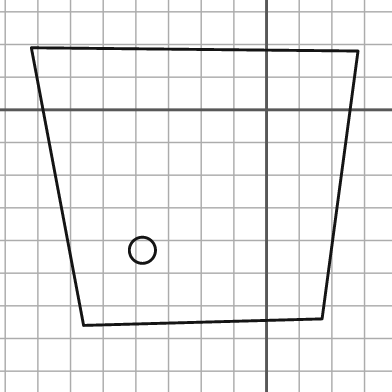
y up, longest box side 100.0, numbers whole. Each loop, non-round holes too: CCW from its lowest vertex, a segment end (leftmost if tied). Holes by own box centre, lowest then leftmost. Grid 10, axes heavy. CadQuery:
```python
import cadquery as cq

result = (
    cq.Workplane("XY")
    .moveTo(-56.0, -66.0)
    .lineTo(17.0, -64.0)
    .lineTo(28.0, 18.0)
    .lineTo(-72.0, 19.0)
    .close()
    .moveTo(-38.0, -43.0)
    .circle(4.0)
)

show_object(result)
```